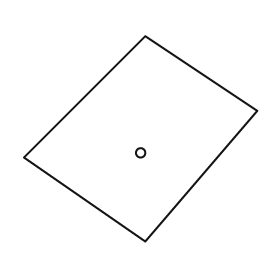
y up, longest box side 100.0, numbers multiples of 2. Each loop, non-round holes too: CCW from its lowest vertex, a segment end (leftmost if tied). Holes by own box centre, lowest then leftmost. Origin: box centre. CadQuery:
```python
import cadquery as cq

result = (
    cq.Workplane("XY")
    .moveTo(2.0, -44.0)
    .lineTo(50.0, 12.0)
    .lineTo(2.0, 44.0)
    .lineTo(-50.0, -8.0)
    .close()
    .moveTo(0.0, -6.0)
    .circle(2.0)
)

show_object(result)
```